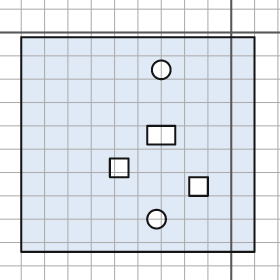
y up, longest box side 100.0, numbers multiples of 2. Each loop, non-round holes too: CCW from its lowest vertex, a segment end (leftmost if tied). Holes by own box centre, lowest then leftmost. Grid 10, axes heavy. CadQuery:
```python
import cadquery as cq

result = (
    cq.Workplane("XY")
    .moveTo(-90.0, -94.0)
    .lineTo(10.0, -94.0)
    .lineTo(10.0, -2.0)
    .lineTo(-90.0, -2.0)
    .close()
    .moveTo(-32.0, -80.0)
    .circle(4.0)
    .moveTo(-18.0, -70.0)
    .lineTo(-10.0, -70.0)
    .lineTo(-10.0, -62.0)
    .lineTo(-18.0, -62.0)
    .close()
    .moveTo(-52.0, -62.0)
    .lineTo(-44.0, -62.0)
    .lineTo(-44.0, -54.0)
    .lineTo(-52.0, -54.0)
    .close()
    .moveTo(-36.0, -48.0)
    .lineTo(-24.0, -48.0)
    .lineTo(-24.0, -40.0)
    .lineTo(-36.0, -40.0)
    .close()
    .moveTo(-30.0, -16.0)
    .circle(4.0)
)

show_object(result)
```